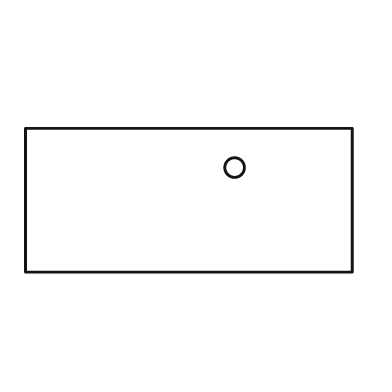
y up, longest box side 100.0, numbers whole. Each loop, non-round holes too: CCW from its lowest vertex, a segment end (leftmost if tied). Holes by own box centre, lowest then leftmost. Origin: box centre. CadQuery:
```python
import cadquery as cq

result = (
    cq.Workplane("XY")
    .moveTo(-50.0, -22.0)
    .lineTo(50.0, -22.0)
    .lineTo(50.0, 22.0)
    .lineTo(-50.0, 22.0)
    .close()
    .moveTo(14.0, 10.0)
    .circle(3.0)
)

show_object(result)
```